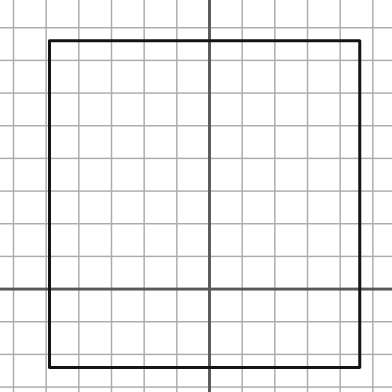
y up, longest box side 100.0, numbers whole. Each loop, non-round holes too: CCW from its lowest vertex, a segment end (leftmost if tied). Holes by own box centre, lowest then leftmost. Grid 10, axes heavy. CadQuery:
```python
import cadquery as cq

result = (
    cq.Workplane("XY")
    .moveTo(-49.0, -24.0)
    .lineTo(46.0, -24.0)
    .lineTo(46.0, 76.0)
    .lineTo(-49.0, 76.0)
    .close()
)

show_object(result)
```